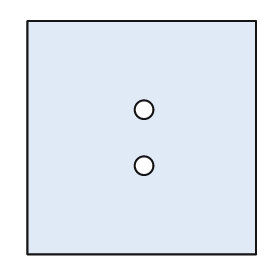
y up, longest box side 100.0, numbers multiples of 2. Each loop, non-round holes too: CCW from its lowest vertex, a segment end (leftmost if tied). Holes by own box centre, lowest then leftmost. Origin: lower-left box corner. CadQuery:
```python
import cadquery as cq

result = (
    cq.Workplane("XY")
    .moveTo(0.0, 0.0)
    .lineTo(98.0, 0.0)
    .lineTo(98.0, 100.0)
    .lineTo(0.0, 100.0)
    .close()
    .moveTo(50.0, 38.0)
    .circle(4.0)
    .moveTo(50.0, 62.0)
    .circle(4.0)
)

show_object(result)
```